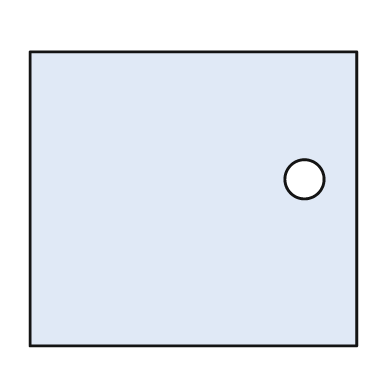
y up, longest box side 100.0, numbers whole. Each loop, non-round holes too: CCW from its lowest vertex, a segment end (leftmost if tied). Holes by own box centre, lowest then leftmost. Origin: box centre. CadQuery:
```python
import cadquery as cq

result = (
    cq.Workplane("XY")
    .moveTo(-50.0, -45.0)
    .lineTo(50.0, -45.0)
    .lineTo(50.0, 45.0)
    .lineTo(-50.0, 45.0)
    .close()
    .moveTo(34.0, 6.0)
    .circle(6.0)
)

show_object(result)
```